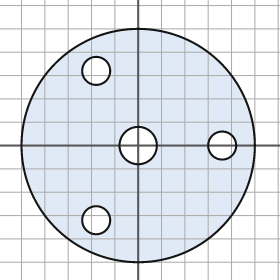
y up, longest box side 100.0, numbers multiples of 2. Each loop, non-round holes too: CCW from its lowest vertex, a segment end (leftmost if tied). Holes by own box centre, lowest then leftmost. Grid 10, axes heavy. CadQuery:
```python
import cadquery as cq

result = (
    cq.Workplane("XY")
    .moveTo(0.0, 0.0)
    .circle(50.0)
    .moveTo(-18.0, -32.0)
    .circle(6.0)
    .moveTo(0.0, 0.0)
    .circle(8.0)
    .moveTo(36.0, 0.0)
    .circle(6.0)
    .moveTo(-18.0, 32.0)
    .circle(6.0)
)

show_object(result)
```